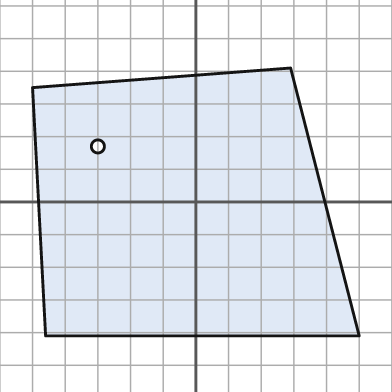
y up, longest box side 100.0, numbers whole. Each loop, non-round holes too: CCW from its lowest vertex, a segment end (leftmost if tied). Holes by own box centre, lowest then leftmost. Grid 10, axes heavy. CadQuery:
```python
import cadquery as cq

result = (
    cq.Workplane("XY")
    .moveTo(-46.0, -41.0)
    .lineTo(50.0, -41.0)
    .lineTo(29.0, 41.0)
    .lineTo(-50.0, 35.0)
    .close()
    .moveTo(-30.0, 17.0)
    .circle(2.0)
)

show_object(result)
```